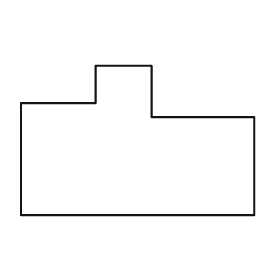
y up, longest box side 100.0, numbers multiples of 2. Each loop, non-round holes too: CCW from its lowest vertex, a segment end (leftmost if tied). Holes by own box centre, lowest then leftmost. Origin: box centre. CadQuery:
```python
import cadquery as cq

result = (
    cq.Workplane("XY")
    .moveTo(-50.0, -32.0)
    .lineTo(50.0, -32.0)
    .lineTo(50.0, 10.0)
    .lineTo(6.0, 10.0)
    .lineTo(6.0, 32.0)
    .lineTo(-18.0, 32.0)
    .lineTo(-18.0, 16.0)
    .lineTo(-50.0, 16.0)
    .close()
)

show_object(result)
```